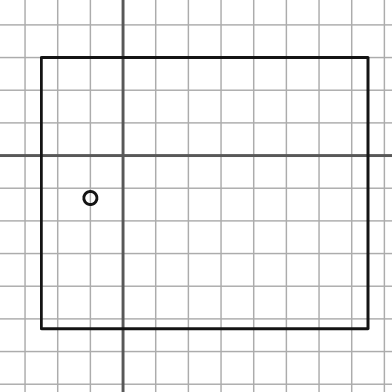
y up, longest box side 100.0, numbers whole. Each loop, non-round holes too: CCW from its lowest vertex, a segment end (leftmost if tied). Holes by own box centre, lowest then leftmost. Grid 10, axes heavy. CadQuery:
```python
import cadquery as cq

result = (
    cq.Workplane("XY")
    .moveTo(-25.0, -53.0)
    .lineTo(75.0, -53.0)
    .lineTo(75.0, 30.0)
    .lineTo(-25.0, 30.0)
    .close()
    .moveTo(-10.0, -13.0)
    .circle(2.0)
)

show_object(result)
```